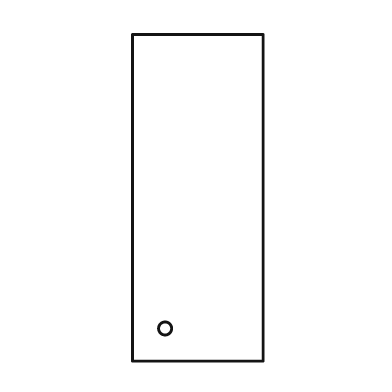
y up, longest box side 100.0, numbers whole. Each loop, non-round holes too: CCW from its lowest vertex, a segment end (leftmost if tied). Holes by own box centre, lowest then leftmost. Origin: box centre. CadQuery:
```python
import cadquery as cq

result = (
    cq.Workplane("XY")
    .moveTo(-20.0, -50.0)
    .lineTo(20.0, -50.0)
    .lineTo(20.0, 50.0)
    .lineTo(-20.0, 50.0)
    .close()
    .moveTo(-10.0, -40.0)
    .circle(2.0)
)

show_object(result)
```